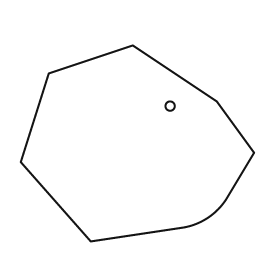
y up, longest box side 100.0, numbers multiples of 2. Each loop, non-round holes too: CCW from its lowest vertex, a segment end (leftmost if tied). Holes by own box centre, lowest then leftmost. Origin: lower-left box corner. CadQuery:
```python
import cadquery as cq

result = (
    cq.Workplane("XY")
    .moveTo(30.0, 0.0)
    .lineTo(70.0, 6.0)
    .threePointArc((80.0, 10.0), (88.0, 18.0))
    .lineTo(100.0, 38.0)
    .lineTo(84.0, 60.0)
    .lineTo(48.0, 84.0)
    .lineTo(12.0, 72.0)
    .lineTo(0.0, 34.0)
    .close()
    .moveTo(64.0, 58.0)
    .circle(2.0)
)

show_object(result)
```